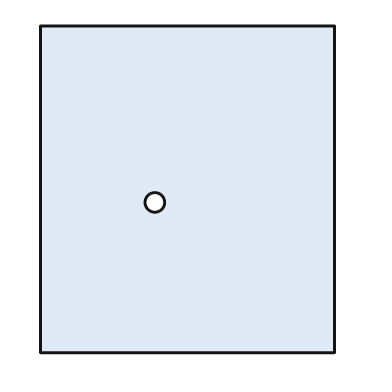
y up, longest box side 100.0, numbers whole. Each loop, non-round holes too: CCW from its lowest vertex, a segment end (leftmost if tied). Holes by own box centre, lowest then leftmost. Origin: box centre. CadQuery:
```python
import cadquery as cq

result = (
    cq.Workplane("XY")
    .moveTo(-45.0, -50.0)
    .lineTo(45.0, -50.0)
    .lineTo(45.0, 50.0)
    .lineTo(-45.0, 50.0)
    .close()
    .moveTo(-10.0, -4.0)
    .circle(3.0)
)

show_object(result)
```